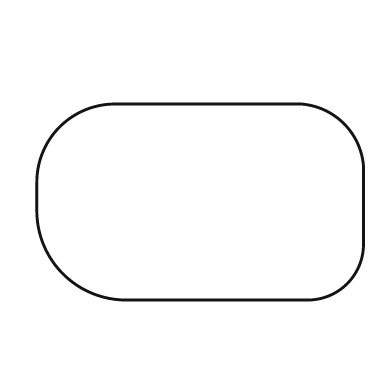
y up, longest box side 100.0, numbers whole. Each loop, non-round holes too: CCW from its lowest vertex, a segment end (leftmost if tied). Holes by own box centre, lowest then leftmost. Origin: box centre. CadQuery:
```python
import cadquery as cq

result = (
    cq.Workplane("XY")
    .moveTo(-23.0, -30.0)
    .lineTo(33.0, -30.0)
    .threePointArc((45.0, -25.0), (50.0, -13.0))
    .lineTo(50.0, 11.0)
    .threePointArc((44.0, 24.0), (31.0, 30.0))
    .lineTo(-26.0, 30.0)
    .threePointArc((-43.0, 23.0), (-50.0, 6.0))
    .lineTo(-50.0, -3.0)
    .threePointArc((-42.0, -22.0), (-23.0, -30.0))
    .close()
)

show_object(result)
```